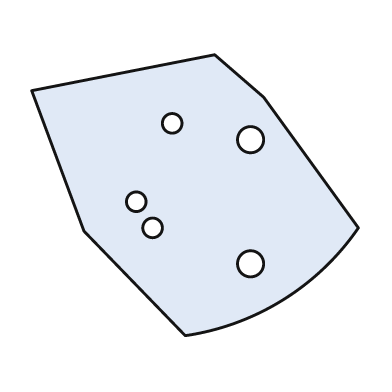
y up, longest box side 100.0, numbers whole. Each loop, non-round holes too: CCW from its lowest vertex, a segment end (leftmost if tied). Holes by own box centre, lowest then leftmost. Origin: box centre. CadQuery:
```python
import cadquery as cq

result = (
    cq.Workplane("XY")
    .moveTo(-3.0, -43.0)
    .threePointArc((27.0, -32.0), (50.0, -10.0))
    .lineTo(21.0, 30.0)
    .lineTo(6.0, 43.0)
    .lineTo(-50.0, 32.0)
    .lineTo(-34.0, -11.0)
    .close()
    .moveTo(17.0, -21.0)
    .circle(4.0)
    .moveTo(-13.0, -10.0)
    .circle(3.0)
    .moveTo(-18.0, -2.0)
    .circle(3.0)
    .moveTo(17.0, 17.0)
    .circle(4.0)
    .moveTo(-7.0, 22.0)
    .circle(3.0)
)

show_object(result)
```